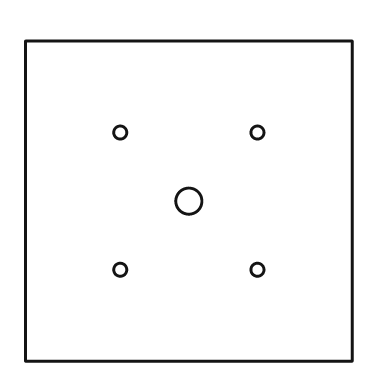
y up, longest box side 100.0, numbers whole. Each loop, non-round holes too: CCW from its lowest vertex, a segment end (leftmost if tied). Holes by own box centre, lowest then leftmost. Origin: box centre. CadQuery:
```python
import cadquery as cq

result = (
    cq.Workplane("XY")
    .moveTo(-50.0, -49.0)
    .lineTo(50.0, -49.0)
    .lineTo(50.0, 49.0)
    .lineTo(-50.0, 49.0)
    .close()
    .moveTo(-21.0, -21.0)
    .circle(2.0)
    .moveTo(21.0, -21.0)
    .circle(2.0)
    .moveTo(0.0, 0.0)
    .circle(4.0)
    .moveTo(-21.0, 21.0)
    .circle(2.0)
    .moveTo(21.0, 21.0)
    .circle(2.0)
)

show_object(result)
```